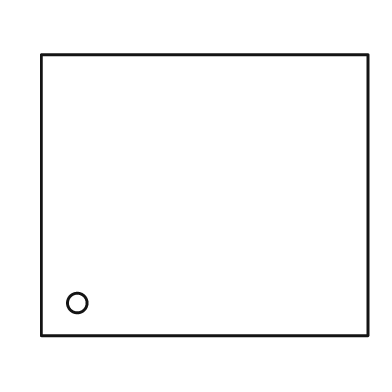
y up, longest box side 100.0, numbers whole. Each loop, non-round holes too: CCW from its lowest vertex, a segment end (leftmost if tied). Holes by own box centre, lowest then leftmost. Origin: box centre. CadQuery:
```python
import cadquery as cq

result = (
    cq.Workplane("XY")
    .moveTo(-50.0, -43.0)
    .lineTo(50.0, -43.0)
    .lineTo(50.0, 43.0)
    .lineTo(-50.0, 43.0)
    .close()
    .moveTo(-39.0, -33.0)
    .circle(3.0)
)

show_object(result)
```